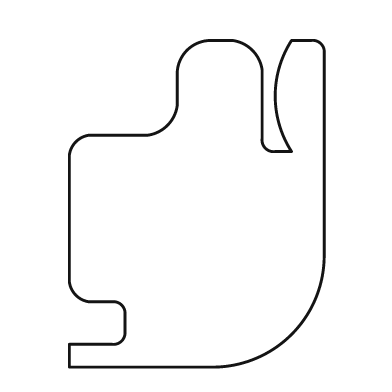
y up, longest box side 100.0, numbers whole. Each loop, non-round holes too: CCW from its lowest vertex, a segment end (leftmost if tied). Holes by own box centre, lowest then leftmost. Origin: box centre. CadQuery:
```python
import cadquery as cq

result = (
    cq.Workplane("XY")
    .moveTo(-39.0, -50.0)
    .lineTo(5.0, -50.0)
    .threePointArc((29.0, -40.0), (39.0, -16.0))
    .lineTo(39.0, 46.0)
    .threePointArc((38.0, 49.0), (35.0, 50.0))
    .lineTo(29.0, 50.0)
    .threePointArc((24.0, 33.0), (29.0, 16.0))
    .lineTo(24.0, 16.0)
    .threePointArc((21.0, 17.0), (20.0, 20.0))
    .lineTo(20.0, 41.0)
    .threePointArc((17.0, 47.0), (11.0, 50.0))
    .lineTo(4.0, 50.0)
    .threePointArc((-3.0, 47.0), (-6.0, 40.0))
    .lineTo(-6.0, 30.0)
    .threePointArc((-9.0, 24.0), (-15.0, 21.0))
    .lineTo(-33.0, 21.0)
    .threePointArc((-37.0, 19.0), (-39.0, 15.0))
    .lineTo(-39.0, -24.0)
    .threePointArc((-37.0, -28.0), (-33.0, -30.0))
    .lineTo(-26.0, -30.0)
    .threePointArc((-23.0, -31.0), (-22.0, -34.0))
    .lineTo(-22.0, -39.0)
    .threePointArc((-23.0, -42.0), (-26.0, -43.0))
    .lineTo(-39.0, -43.0)
    .close()
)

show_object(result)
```